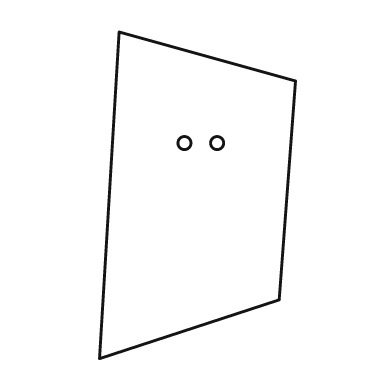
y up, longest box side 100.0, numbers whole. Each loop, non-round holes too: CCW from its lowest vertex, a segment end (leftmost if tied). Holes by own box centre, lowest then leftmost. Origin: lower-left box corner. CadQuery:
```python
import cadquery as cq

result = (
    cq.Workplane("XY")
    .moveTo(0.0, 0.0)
    .lineTo(55.0, 18.0)
    .lineTo(60.0, 85.0)
    .lineTo(6.0, 100.0)
    .close()
    .moveTo(26.0, 66.0)
    .circle(2.0)
    .moveTo(36.0, 66.0)
    .circle(2.0)
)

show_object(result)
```